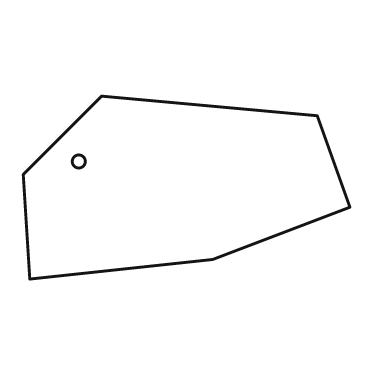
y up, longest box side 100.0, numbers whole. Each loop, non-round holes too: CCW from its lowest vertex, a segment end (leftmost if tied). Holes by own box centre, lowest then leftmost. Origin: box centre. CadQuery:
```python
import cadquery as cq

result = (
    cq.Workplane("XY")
    .moveTo(-48.0, -28.0)
    .lineTo(8.0, -22.0)
    .lineTo(50.0, -6.0)
    .lineTo(40.0, 22.0)
    .lineTo(-26.0, 28.0)
    .lineTo(-50.0, 4.0)
    .close()
    .moveTo(-33.0, 8.0)
    .circle(2.0)
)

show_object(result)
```